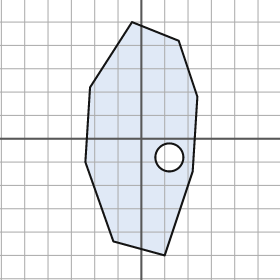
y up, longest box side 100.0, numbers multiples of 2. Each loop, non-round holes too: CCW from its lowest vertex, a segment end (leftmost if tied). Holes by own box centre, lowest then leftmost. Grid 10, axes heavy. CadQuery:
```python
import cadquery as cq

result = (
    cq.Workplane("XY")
    .moveTo(10.0, -50.0)
    .lineTo(22.0, -14.0)
    .lineTo(24.0, 18.0)
    .lineTo(16.0, 42.0)
    .lineTo(-4.0, 50.0)
    .lineTo(-22.0, 22.0)
    .lineTo(-24.0, -10.0)
    .lineTo(-12.0, -44.0)
    .close()
    .moveTo(12.0, -8.0)
    .circle(6.0)
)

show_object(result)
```